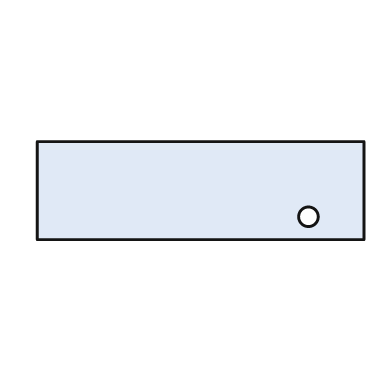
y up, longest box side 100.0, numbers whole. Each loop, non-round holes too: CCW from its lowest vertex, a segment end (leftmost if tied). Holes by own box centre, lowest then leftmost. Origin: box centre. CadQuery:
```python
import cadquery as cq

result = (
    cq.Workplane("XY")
    .moveTo(-50.0, -15.0)
    .lineTo(50.0, -15.0)
    .lineTo(50.0, 15.0)
    .lineTo(-50.0, 15.0)
    .close()
    .moveTo(33.0, -8.0)
    .circle(3.0)
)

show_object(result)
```